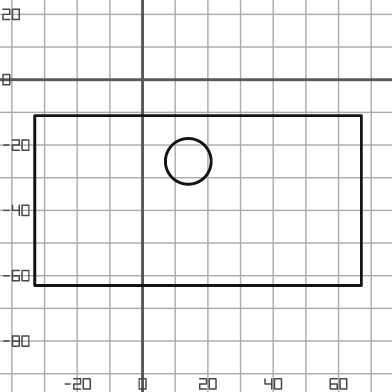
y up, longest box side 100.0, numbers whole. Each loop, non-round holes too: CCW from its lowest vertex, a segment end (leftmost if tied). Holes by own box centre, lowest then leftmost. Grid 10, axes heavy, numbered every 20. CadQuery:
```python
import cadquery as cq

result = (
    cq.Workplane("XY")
    .moveTo(-33.0, -63.0)
    .lineTo(67.0, -63.0)
    .lineTo(67.0, -11.0)
    .lineTo(-33.0, -11.0)
    .close()
    .moveTo(14.0, -25.0)
    .circle(7.0)
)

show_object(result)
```